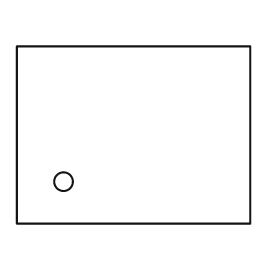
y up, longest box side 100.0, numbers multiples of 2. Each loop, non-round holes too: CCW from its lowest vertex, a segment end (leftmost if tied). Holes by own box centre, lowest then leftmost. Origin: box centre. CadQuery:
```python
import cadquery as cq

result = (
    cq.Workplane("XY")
    .moveTo(-50.0, -38.0)
    .lineTo(50.0, -38.0)
    .lineTo(50.0, 38.0)
    .lineTo(-50.0, 38.0)
    .close()
    .moveTo(-30.0, -20.0)
    .circle(4.0)
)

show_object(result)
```